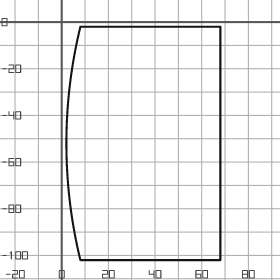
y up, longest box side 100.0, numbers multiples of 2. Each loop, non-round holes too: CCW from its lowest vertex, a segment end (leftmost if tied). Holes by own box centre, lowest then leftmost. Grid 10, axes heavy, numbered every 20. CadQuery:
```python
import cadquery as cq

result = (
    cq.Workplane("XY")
    .moveTo(8.0, -102.0)
    .lineTo(68.0, -102.0)
    .lineTo(68.0, -2.0)
    .lineTo(8.0, -2.0)
    .threePointArc((2.0, -52.0), (8.0, -102.0))
    .close()
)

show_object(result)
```